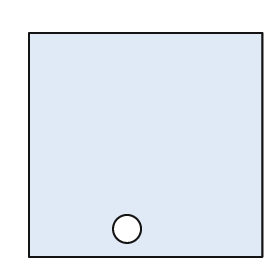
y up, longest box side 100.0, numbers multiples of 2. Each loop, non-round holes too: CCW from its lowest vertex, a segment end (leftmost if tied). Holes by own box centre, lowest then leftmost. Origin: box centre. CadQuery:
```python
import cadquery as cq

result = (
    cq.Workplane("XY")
    .moveTo(-50.0, -48.0)
    .lineTo(50.0, -48.0)
    .lineTo(50.0, 48.0)
    .lineTo(-50.0, 48.0)
    .close()
    .moveTo(-8.0, -36.0)
    .circle(6.0)
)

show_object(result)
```